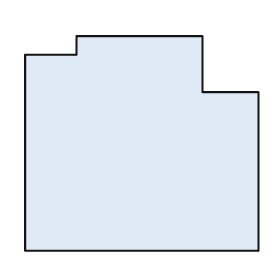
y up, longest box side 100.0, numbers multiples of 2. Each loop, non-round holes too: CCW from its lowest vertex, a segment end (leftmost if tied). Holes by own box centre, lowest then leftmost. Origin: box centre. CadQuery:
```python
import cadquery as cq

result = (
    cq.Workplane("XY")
    .moveTo(-50.0, -46.0)
    .lineTo(50.0, -46.0)
    .lineTo(50.0, 22.0)
    .lineTo(26.0, 22.0)
    .lineTo(26.0, 46.0)
    .lineTo(-28.0, 46.0)
    .lineTo(-28.0, 38.0)
    .lineTo(-50.0, 38.0)
    .close()
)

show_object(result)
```